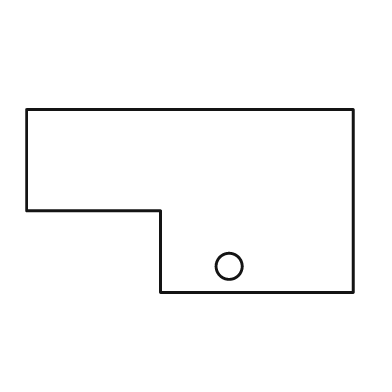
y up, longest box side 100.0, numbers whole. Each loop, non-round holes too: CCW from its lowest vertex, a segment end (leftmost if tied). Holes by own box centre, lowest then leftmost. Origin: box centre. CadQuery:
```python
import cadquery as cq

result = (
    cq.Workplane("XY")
    .moveTo(-9.0, -28.0)
    .lineTo(50.0, -28.0)
    .lineTo(50.0, 28.0)
    .lineTo(-50.0, 28.0)
    .lineTo(-50.0, -3.0)
    .lineTo(-9.0, -3.0)
    .close()
    .moveTo(12.0, -20.0)
    .circle(4.0)
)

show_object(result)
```